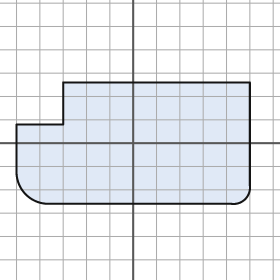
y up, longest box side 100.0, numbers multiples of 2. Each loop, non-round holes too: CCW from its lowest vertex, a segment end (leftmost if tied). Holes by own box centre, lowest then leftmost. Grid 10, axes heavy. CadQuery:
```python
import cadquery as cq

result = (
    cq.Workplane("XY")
    .moveTo(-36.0, -26.0)
    .lineTo(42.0, -26.0)
    .threePointArc((48.0, -24.0), (50.0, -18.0))
    .lineTo(50.0, 26.0)
    .lineTo(-30.0, 26.0)
    .lineTo(-30.0, 8.0)
    .lineTo(-50.0, 8.0)
    .lineTo(-50.0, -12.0)
    .threePointArc((-46.0, -22.0), (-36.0, -26.0))
    .close()
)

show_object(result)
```